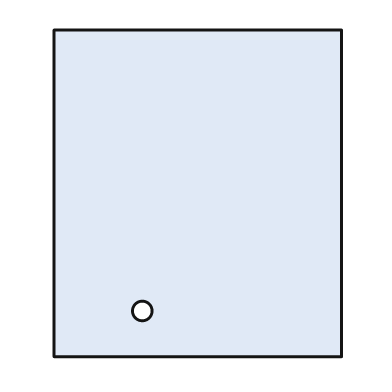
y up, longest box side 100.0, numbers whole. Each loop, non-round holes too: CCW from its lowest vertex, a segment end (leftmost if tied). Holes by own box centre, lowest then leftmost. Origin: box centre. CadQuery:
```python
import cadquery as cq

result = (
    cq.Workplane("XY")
    .moveTo(-44.0, -50.0)
    .lineTo(44.0, -50.0)
    .lineTo(44.0, 50.0)
    .lineTo(-44.0, 50.0)
    .close()
    .moveTo(-17.0, -36.0)
    .circle(3.0)
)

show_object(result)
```